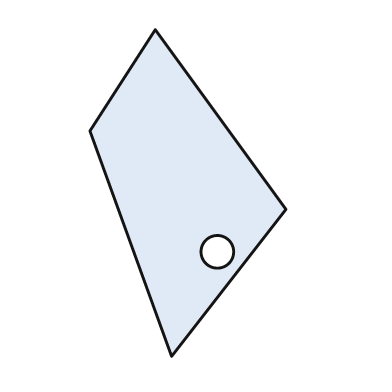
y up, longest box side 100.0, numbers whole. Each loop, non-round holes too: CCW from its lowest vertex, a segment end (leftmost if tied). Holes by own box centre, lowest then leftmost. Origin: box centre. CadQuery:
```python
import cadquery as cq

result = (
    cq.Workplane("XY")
    .moveTo(-5.0, -50.0)
    .lineTo(30.0, -5.0)
    .lineTo(-10.0, 50.0)
    .lineTo(-30.0, 19.0)
    .close()
    .moveTo(9.0, -18.0)
    .circle(5.0)
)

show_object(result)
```